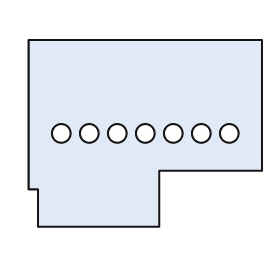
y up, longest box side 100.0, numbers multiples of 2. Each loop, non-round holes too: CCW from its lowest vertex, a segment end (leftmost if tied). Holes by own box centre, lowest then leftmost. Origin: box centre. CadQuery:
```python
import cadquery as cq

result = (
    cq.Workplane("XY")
    .moveTo(-46.0, -40.0)
    .lineTo(6.0, -40.0)
    .lineTo(6.0, -16.0)
    .lineTo(50.0, -16.0)
    .lineTo(50.0, 40.0)
    .lineTo(-50.0, 40.0)
    .lineTo(-50.0, -24.0)
    .lineTo(-46.0, -24.0)
    .close()
    .moveTo(-36.0, 0.0)
    .circle(4.0)
    .moveTo(-24.0, 0.0)
    .circle(4.0)
    .moveTo(-12.0, 0.0)
    .circle(4.0)
    .moveTo(0.0, 0.0)
    .circle(4.0)
    .moveTo(12.0, 0.0)
    .circle(4.0)
    .moveTo(24.0, 0.0)
    .circle(4.0)
    .moveTo(36.0, 0.0)
    .circle(4.0)
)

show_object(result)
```